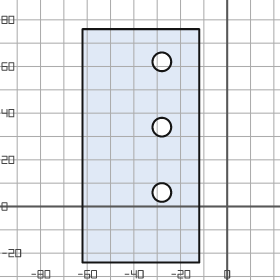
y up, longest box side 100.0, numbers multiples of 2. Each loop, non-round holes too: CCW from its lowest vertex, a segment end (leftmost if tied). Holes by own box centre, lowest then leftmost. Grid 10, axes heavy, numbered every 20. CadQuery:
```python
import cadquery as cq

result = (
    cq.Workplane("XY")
    .moveTo(-62.0, -24.0)
    .lineTo(-12.0, -24.0)
    .lineTo(-12.0, 76.0)
    .lineTo(-62.0, 76.0)
    .close()
    .moveTo(-28.0, 6.0)
    .circle(4.0)
    .moveTo(-28.0, 34.0)
    .circle(4.0)
    .moveTo(-28.0, 62.0)
    .circle(4.0)
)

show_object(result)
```